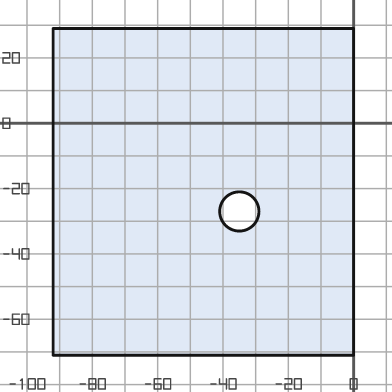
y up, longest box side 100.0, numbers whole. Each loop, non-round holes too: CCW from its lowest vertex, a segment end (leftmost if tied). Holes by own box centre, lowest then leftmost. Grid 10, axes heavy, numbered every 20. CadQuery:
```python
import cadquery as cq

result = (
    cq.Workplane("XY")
    .moveTo(-92.0, -71.0)
    .lineTo(0.0, -71.0)
    .lineTo(0.0, 29.0)
    .lineTo(-92.0, 29.0)
    .close()
    .moveTo(-35.0, -27.0)
    .circle(6.0)
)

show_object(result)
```